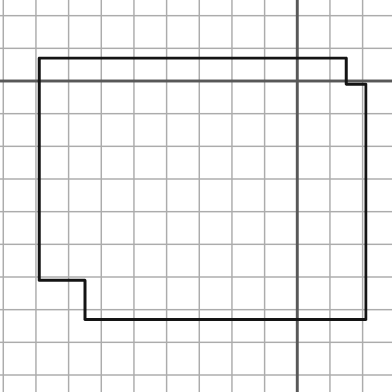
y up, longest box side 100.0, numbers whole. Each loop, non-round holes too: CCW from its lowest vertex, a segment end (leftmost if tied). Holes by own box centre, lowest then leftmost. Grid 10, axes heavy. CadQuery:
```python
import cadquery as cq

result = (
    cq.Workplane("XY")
    .moveTo(-65.0, -73.0)
    .lineTo(21.0, -73.0)
    .lineTo(21.0, -1.0)
    .lineTo(15.0, -1.0)
    .lineTo(15.0, 7.0)
    .lineTo(-79.0, 7.0)
    .lineTo(-79.0, -61.0)
    .lineTo(-65.0, -61.0)
    .close()
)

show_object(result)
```